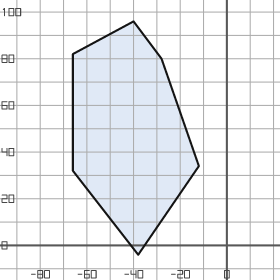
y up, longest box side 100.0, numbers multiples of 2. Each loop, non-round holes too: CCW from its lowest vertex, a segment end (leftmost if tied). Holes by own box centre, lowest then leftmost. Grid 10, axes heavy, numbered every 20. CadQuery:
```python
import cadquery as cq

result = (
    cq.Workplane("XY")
    .moveTo(-38.0, -4.0)
    .lineTo(-12.0, 34.0)
    .lineTo(-28.0, 80.0)
    .lineTo(-40.0, 96.0)
    .lineTo(-66.0, 82.0)
    .lineTo(-66.0, 32.0)
    .close()
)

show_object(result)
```